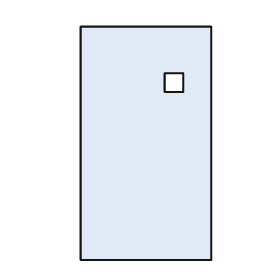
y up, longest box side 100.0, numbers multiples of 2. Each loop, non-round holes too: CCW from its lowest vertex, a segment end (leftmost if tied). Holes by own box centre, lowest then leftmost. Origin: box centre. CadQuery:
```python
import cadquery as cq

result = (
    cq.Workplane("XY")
    .moveTo(-28.0, -50.0)
    .lineTo(28.0, -50.0)
    .lineTo(28.0, 50.0)
    .lineTo(-28.0, 50.0)
    .close()
    .moveTo(8.0, 22.0)
    .lineTo(16.0, 22.0)
    .lineTo(16.0, 30.0)
    .lineTo(8.0, 30.0)
    .close()
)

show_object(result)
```